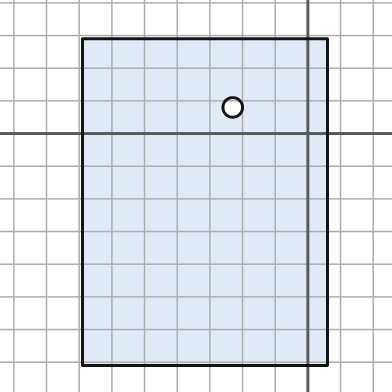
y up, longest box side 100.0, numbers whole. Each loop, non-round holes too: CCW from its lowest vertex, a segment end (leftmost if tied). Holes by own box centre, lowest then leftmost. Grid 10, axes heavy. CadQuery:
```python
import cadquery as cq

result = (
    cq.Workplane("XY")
    .moveTo(-69.0, -71.0)
    .lineTo(6.0, -71.0)
    .lineTo(6.0, 29.0)
    .lineTo(-69.0, 29.0)
    .close()
    .moveTo(-23.0, 8.0)
    .circle(3.0)
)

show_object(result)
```